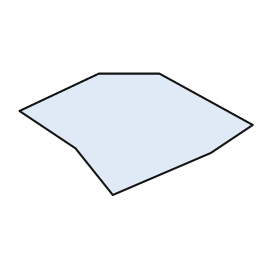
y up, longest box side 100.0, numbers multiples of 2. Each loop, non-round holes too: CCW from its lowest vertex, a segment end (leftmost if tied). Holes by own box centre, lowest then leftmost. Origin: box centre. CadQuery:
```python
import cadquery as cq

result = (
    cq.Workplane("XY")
    .moveTo(-10.0, -26.0)
    .lineTo(32.0, -8.0)
    .lineTo(50.0, 4.0)
    .lineTo(10.0, 26.0)
    .lineTo(-16.0, 26.0)
    .lineTo(-50.0, 10.0)
    .lineTo(-26.0, -6.0)
    .close()
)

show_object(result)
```